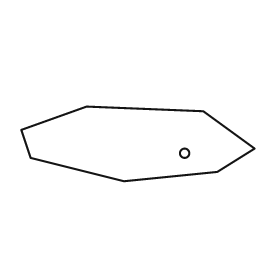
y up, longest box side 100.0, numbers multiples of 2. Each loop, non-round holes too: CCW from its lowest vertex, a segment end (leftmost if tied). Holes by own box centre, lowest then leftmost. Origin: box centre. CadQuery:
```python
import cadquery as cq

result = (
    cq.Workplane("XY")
    .moveTo(-6.0, -16.0)
    .lineTo(34.0, -12.0)
    .lineTo(50.0, -2.0)
    .lineTo(28.0, 14.0)
    .lineTo(-22.0, 16.0)
    .lineTo(-50.0, 6.0)
    .lineTo(-46.0, -6.0)
    .close()
    .moveTo(20.0, -4.0)
    .circle(2.0)
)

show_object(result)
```